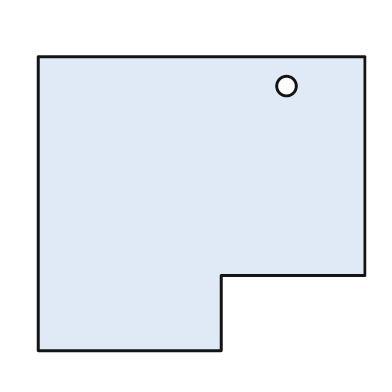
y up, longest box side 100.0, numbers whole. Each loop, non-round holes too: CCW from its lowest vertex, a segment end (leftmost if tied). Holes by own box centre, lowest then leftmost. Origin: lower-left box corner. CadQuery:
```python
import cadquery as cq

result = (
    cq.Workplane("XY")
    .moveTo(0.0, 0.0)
    .lineTo(56.0, 0.0)
    .lineTo(56.0, 23.0)
    .lineTo(100.0, 23.0)
    .lineTo(100.0, 90.0)
    .lineTo(0.0, 90.0)
    .close()
    .moveTo(76.0, 81.0)
    .circle(3.0)
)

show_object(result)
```